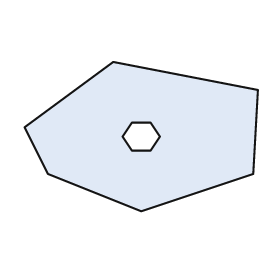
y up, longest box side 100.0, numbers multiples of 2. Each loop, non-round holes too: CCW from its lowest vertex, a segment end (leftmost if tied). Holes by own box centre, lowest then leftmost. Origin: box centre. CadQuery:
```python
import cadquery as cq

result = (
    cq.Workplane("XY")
    .moveTo(0.0, -32.0)
    .lineTo(48.0, -16.0)
    .lineTo(50.0, 20.0)
    .lineTo(-12.0, 32.0)
    .lineTo(-50.0, 4.0)
    .lineTo(-40.0, -16.0)
    .close()
    .moveTo(-4.0, -6.0)
    .lineTo(4.0, -6.0)
    .lineTo(8.0, 0.0)
    .lineTo(4.0, 6.0)
    .lineTo(-4.0, 6.0)
    .lineTo(-8.0, 0.0)
    .close()
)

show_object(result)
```